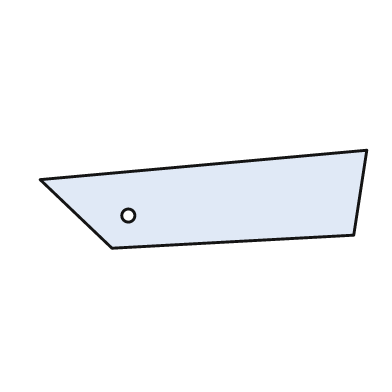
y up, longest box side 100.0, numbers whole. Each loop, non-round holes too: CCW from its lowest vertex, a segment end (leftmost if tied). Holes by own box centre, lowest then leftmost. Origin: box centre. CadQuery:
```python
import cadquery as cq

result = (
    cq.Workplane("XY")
    .moveTo(-28.0, -15.0)
    .lineTo(46.0, -11.0)
    .lineTo(50.0, 15.0)
    .lineTo(-50.0, 6.0)
    .close()
    .moveTo(-23.0, -5.0)
    .circle(2.0)
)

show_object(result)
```